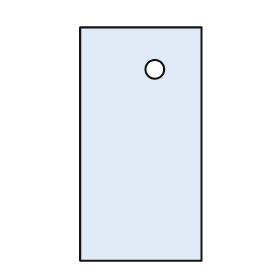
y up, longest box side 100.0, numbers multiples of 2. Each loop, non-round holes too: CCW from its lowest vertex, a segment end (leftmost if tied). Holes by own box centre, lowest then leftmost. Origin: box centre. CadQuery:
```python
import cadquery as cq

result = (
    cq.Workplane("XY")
    .moveTo(-26.0, -50.0)
    .lineTo(26.0, -50.0)
    .lineTo(26.0, 50.0)
    .lineTo(-26.0, 50.0)
    .close()
    .moveTo(6.0, 32.0)
    .circle(4.0)
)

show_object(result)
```